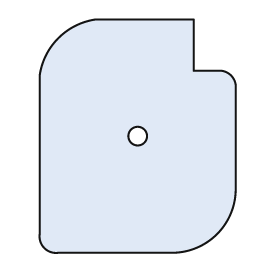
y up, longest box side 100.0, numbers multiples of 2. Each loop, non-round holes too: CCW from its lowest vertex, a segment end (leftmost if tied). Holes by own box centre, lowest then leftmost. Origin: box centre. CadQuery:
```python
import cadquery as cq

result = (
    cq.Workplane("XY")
    .moveTo(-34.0, -50.0)
    .lineTo(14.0, -50.0)
    .threePointArc((34.0, -42.0), (42.0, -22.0))
    .lineTo(42.0, 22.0)
    .threePointArc((40.0, 26.0), (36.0, 28.0))
    .lineTo(24.0, 28.0)
    .lineTo(24.0, 50.0)
    .lineTo(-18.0, 50.0)
    .threePointArc((-34.0, 42.0), (-42.0, 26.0))
    .lineTo(-42.0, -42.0)
    .threePointArc((-40.0, -48.0), (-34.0, -50.0))
    .close()
    .moveTo(0.0, 0.0)
    .circle(4.0)
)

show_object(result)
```